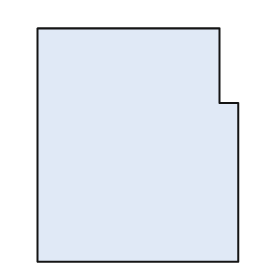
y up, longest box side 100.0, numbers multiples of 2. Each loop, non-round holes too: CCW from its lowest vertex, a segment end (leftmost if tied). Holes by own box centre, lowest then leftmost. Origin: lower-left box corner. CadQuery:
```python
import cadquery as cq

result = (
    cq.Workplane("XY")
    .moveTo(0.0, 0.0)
    .lineTo(86.0, 0.0)
    .lineTo(86.0, 68.0)
    .lineTo(78.0, 68.0)
    .lineTo(78.0, 100.0)
    .lineTo(0.0, 100.0)
    .close()
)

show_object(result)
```